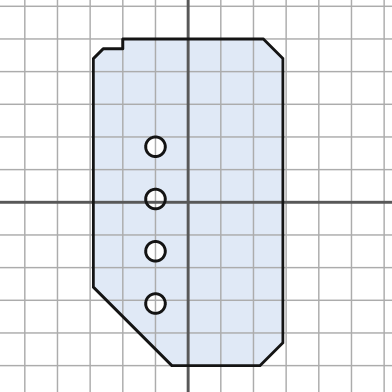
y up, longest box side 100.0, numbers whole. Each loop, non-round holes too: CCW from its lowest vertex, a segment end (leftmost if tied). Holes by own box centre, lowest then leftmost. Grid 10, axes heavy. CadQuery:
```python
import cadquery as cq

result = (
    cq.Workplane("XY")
    .moveTo(-5.0, -50.0)
    .lineTo(22.0, -50.0)
    .lineTo(29.0, -43.0)
    .lineTo(29.0, 44.0)
    .lineTo(23.0, 50.0)
    .lineTo(-20.0, 50.0)
    .lineTo(-20.0, 47.0)
    .lineTo(-26.0, 47.0)
    .lineTo(-29.0, 44.0)
    .lineTo(-29.0, -26.0)
    .close()
    .moveTo(-10.0, -31.0)
    .circle(3.0)
    .moveTo(-10.0, -15.0)
    .circle(3.0)
    .moveTo(-10.0, 1.0)
    .circle(3.0)
    .moveTo(-10.0, 17.0)
    .circle(3.0)
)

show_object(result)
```